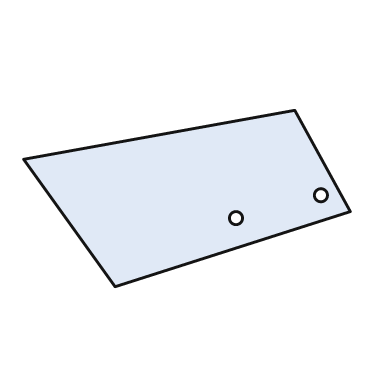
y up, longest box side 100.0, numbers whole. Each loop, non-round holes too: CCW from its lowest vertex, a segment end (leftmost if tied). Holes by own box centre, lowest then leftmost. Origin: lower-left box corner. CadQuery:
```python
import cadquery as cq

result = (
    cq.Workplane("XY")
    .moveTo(28.0, 0.0)
    .lineTo(100.0, 23.0)
    .lineTo(83.0, 54.0)
    .lineTo(0.0, 39.0)
    .close()
    .moveTo(65.0, 21.0)
    .circle(2.0)
    .moveTo(91.0, 28.0)
    .circle(2.0)
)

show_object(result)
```